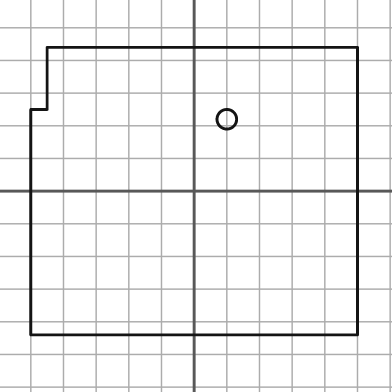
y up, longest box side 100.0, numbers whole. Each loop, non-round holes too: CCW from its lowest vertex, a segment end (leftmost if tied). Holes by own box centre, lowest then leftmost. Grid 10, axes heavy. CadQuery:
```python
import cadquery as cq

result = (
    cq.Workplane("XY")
    .moveTo(-50.0, -44.0)
    .lineTo(50.0, -44.0)
    .lineTo(50.0, 44.0)
    .lineTo(-45.0, 44.0)
    .lineTo(-45.0, 25.0)
    .lineTo(-50.0, 25.0)
    .close()
    .moveTo(10.0, 22.0)
    .circle(3.0)
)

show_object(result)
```